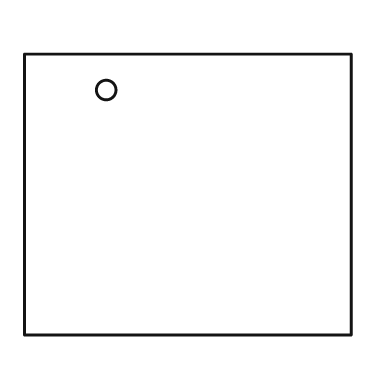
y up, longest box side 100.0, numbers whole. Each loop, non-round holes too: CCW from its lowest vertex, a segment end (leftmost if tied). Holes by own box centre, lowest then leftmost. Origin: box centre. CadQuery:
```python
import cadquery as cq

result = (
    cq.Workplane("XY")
    .moveTo(-50.0, -43.0)
    .lineTo(50.0, -43.0)
    .lineTo(50.0, 43.0)
    .lineTo(-50.0, 43.0)
    .close()
    .moveTo(-25.0, 32.0)
    .circle(3.0)
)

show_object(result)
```